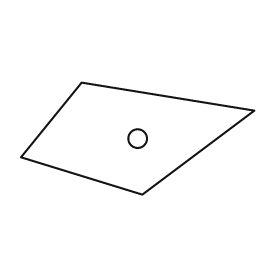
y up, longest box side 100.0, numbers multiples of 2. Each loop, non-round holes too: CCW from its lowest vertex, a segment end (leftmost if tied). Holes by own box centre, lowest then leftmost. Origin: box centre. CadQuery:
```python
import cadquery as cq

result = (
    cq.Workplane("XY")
    .moveTo(2.0, -24.0)
    .lineTo(50.0, 12.0)
    .lineTo(-24.0, 24.0)
    .lineTo(-50.0, -8.0)
    .close()
    .moveTo(0.0, 0.0)
    .circle(4.0)
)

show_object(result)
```